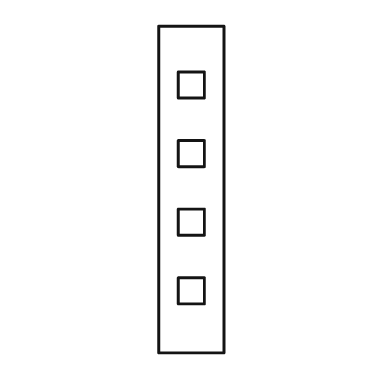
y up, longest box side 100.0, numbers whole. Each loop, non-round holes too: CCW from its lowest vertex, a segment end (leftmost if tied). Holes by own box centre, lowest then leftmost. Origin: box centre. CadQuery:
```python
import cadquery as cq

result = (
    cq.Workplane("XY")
    .moveTo(-10.0, -50.0)
    .lineTo(10.0, -50.0)
    .lineTo(10.0, 50.0)
    .lineTo(-10.0, 50.0)
    .close()
    .moveTo(-4.0, -35.0)
    .lineTo(4.0, -35.0)
    .lineTo(4.0, -27.0)
    .lineTo(-4.0, -27.0)
    .close()
    .moveTo(-4.0, -14.0)
    .lineTo(4.0, -14.0)
    .lineTo(4.0, -6.0)
    .lineTo(-4.0, -6.0)
    .close()
    .moveTo(-4.0, 7.0)
    .lineTo(4.0, 7.0)
    .lineTo(4.0, 15.0)
    .lineTo(-4.0, 15.0)
    .close()
    .moveTo(-4.0, 28.0)
    .lineTo(4.0, 28.0)
    .lineTo(4.0, 36.0)
    .lineTo(-4.0, 36.0)
    .close()
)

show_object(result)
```